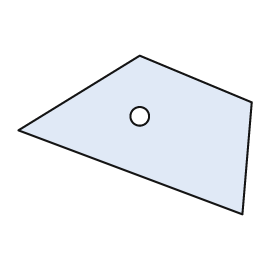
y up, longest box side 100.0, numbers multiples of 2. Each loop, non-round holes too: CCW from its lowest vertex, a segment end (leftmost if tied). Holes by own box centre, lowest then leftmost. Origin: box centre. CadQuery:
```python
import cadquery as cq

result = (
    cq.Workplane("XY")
    .moveTo(46.0, -34.0)
    .lineTo(50.0, 14.0)
    .lineTo(2.0, 34.0)
    .lineTo(-50.0, 2.0)
    .close()
    .moveTo(2.0, 8.0)
    .circle(4.0)
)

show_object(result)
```